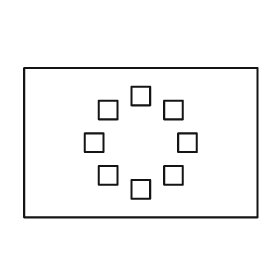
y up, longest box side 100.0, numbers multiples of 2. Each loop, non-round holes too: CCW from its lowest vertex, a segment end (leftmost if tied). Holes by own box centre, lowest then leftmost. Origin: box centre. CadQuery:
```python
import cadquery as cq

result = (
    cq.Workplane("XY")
    .moveTo(-50.0, -32.0)
    .lineTo(50.0, -32.0)
    .lineTo(50.0, 32.0)
    .lineTo(-50.0, 32.0)
    .close()
    .moveTo(-4.0, -24.0)
    .lineTo(4.0, -24.0)
    .lineTo(4.0, -16.0)
    .lineTo(-4.0, -16.0)
    .close()
    .moveTo(-18.0, -18.0)
    .lineTo(-10.0, -18.0)
    .lineTo(-10.0, -10.0)
    .lineTo(-18.0, -10.0)
    .close()
    .moveTo(10.0, -18.0)
    .lineTo(18.0, -18.0)
    .lineTo(18.0, -10.0)
    .lineTo(10.0, -10.0)
    .close()
    .moveTo(-24.0, -4.0)
    .lineTo(-16.0, -4.0)
    .lineTo(-16.0, 4.0)
    .lineTo(-24.0, 4.0)
    .close()
    .moveTo(16.0, -4.0)
    .lineTo(24.0, -4.0)
    .lineTo(24.0, 4.0)
    .lineTo(16.0, 4.0)
    .close()
    .moveTo(-18.0, 10.0)
    .lineTo(-10.0, 10.0)
    .lineTo(-10.0, 18.0)
    .lineTo(-18.0, 18.0)
    .close()
    .moveTo(10.0, 10.0)
    .lineTo(18.0, 10.0)
    .lineTo(18.0, 18.0)
    .lineTo(10.0, 18.0)
    .close()
    .moveTo(-4.0, 16.0)
    .lineTo(4.0, 16.0)
    .lineTo(4.0, 24.0)
    .lineTo(-4.0, 24.0)
    .close()
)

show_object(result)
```